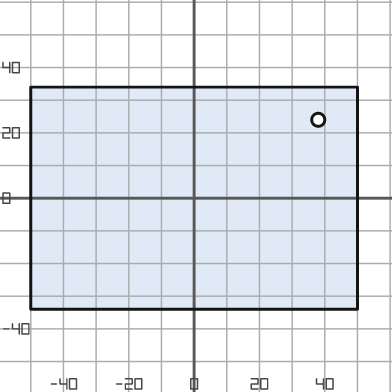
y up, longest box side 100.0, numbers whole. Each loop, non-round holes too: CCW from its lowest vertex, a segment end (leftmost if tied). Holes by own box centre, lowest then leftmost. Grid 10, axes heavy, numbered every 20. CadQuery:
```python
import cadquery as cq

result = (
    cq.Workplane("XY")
    .moveTo(-50.0, -34.0)
    .lineTo(50.0, -34.0)
    .lineTo(50.0, 34.0)
    .lineTo(-50.0, 34.0)
    .close()
    .moveTo(38.0, 24.0)
    .circle(2.0)
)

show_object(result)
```